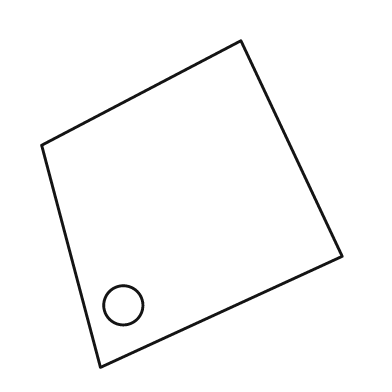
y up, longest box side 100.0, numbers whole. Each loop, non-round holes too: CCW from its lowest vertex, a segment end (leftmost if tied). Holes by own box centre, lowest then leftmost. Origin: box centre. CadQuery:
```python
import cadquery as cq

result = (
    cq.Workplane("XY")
    .moveTo(-28.0, -50.0)
    .lineTo(46.0, -16.0)
    .lineTo(15.0, 50.0)
    .lineTo(-46.0, 18.0)
    .close()
    .moveTo(-21.0, -31.0)
    .circle(6.0)
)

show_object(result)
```